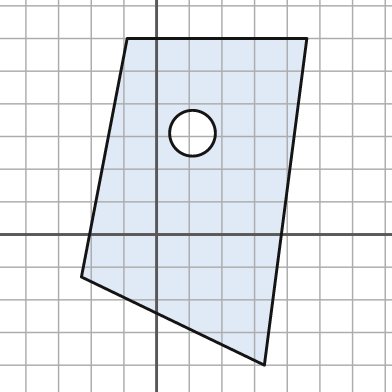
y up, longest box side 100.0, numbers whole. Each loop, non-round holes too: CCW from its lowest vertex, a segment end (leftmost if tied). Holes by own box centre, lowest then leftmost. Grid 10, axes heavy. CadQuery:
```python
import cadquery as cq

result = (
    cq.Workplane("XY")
    .moveTo(33.0, -40.0)
    .lineTo(46.0, 60.0)
    .lineTo(-9.0, 60.0)
    .lineTo(-23.0, -13.0)
    .close()
    .moveTo(11.0, 31.0)
    .circle(7.0)
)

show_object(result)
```